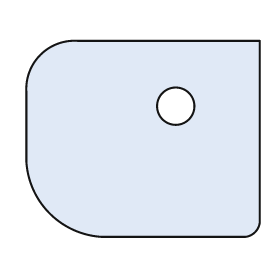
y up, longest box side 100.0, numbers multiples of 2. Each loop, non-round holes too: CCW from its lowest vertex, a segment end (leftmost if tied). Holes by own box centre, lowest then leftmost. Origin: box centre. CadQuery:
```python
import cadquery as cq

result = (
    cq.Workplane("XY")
    .moveTo(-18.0, -42.0)
    .lineTo(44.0, -42.0)
    .threePointArc((48.0, -40.0), (50.0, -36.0))
    .lineTo(50.0, 42.0)
    .lineTo(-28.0, 42.0)
    .threePointArc((-44.0, 36.0), (-50.0, 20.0))
    .lineTo(-50.0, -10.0)
    .threePointArc((-40.0, -32.0), (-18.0, -42.0))
    .close()
    .moveTo(14.0, 14.0)
    .circle(8.0)
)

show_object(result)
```